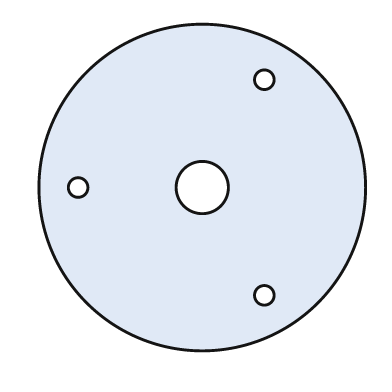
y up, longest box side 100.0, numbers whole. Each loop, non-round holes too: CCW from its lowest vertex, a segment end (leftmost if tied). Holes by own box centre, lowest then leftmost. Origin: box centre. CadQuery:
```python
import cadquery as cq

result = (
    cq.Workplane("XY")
    .moveTo(0.0, 0.0)
    .circle(50.0)
    .moveTo(19.0, -33.0)
    .circle(3.0)
    .moveTo(-38.0, 0.0)
    .circle(3.0)
    .moveTo(0.0, 0.0)
    .circle(8.0)
    .moveTo(19.0, 33.0)
    .circle(3.0)
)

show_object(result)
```